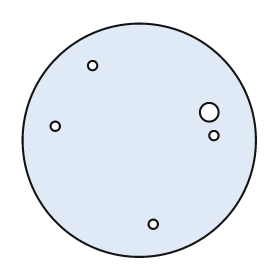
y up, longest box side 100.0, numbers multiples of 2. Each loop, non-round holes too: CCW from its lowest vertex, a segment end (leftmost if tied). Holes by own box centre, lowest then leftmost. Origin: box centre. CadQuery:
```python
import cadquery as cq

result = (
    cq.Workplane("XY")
    .moveTo(0.0, 0.0)
    .circle(50.0)
    .moveTo(6.0, -36.0)
    .circle(2.0)
    .moveTo(32.0, 2.0)
    .circle(2.0)
    .moveTo(-36.0, 6.0)
    .circle(2.0)
    .moveTo(30.0, 12.0)
    .circle(4.0)
    .moveTo(-20.0, 32.0)
    .circle(2.0)
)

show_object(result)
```